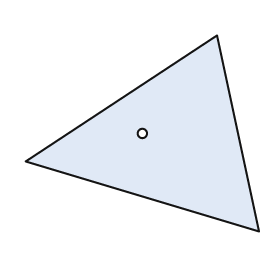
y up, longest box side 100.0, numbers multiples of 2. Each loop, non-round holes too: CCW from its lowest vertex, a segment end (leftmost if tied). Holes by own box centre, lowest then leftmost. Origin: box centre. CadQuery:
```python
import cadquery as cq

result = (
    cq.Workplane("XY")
    .moveTo(50.0, -42.0)
    .lineTo(32.0, 42.0)
    .lineTo(-50.0, -12.0)
    .close()
    .moveTo(0.0, 0.0)
    .circle(2.0)
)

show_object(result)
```